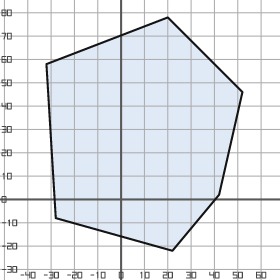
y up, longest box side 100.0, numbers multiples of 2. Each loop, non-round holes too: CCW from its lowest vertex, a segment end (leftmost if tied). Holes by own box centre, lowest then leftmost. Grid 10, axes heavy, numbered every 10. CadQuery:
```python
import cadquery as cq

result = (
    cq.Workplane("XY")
    .moveTo(22.0, -22.0)
    .lineTo(42.0, 2.0)
    .lineTo(52.0, 46.0)
    .lineTo(20.0, 78.0)
    .lineTo(-32.0, 58.0)
    .lineTo(-28.0, -8.0)
    .close()
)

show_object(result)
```